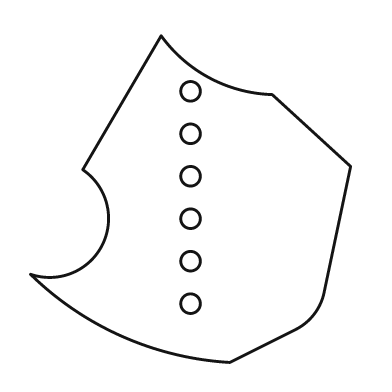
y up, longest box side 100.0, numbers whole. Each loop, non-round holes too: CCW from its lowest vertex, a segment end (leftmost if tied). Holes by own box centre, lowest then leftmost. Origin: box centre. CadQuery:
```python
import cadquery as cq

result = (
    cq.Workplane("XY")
    .moveTo(12.0, -50.0)
    .lineTo(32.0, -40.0)
    .threePointArc((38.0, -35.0), (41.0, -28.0))
    .lineTo(49.0, 10.0)
    .lineTo(25.0, 32.0)
    .threePointArc((6.0, 37.0), (-9.0, 50.0))
    .lineTo(-33.0, 9.0)
    .threePointArc((-27.0, -14.0), (-49.0, -23.0))
    .threePointArc((-21.0, -42.0), (12.0, -50.0))
    .close()
    .moveTo(0.0, -32.0)
    .circle(3.0)
    .moveTo(0.0, -19.0)
    .circle(3.0)
    .moveTo(0.0, -6.0)
    .circle(3.0)
    .moveTo(0.0, 7.0)
    .circle(3.0)
    .moveTo(0.0, 20.0)
    .circle(3.0)
    .moveTo(0.0, 33.0)
    .circle(3.0)
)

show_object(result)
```